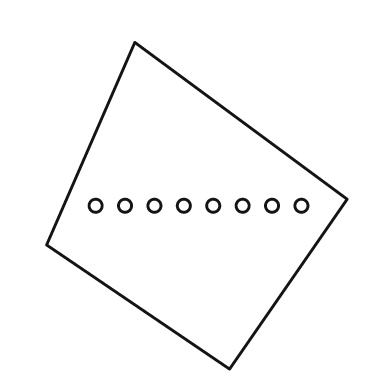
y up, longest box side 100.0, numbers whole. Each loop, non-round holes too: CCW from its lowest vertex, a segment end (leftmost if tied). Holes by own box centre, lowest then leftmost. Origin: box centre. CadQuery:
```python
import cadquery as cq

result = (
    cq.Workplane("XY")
    .moveTo(10.0, -50.0)
    .lineTo(46.0, 2.0)
    .lineTo(-19.0, 50.0)
    .lineTo(-46.0, -12.0)
    .close()
    .moveTo(-31.0, 0.0)
    .circle(2.0)
    .moveTo(-22.0, 0.0)
    .circle(2.0)
    .moveTo(-13.0, 0.0)
    .circle(2.0)
    .moveTo(-4.0, 0.0)
    .circle(2.0)
    .moveTo(5.0, 0.0)
    .circle(2.0)
    .moveTo(14.0, 0.0)
    .circle(2.0)
    .moveTo(23.0, 0.0)
    .circle(2.0)
    .moveTo(32.0, 0.0)
    .circle(2.0)
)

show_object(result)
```